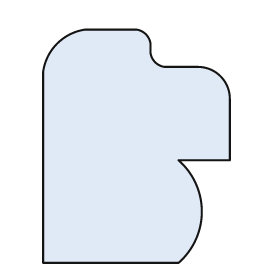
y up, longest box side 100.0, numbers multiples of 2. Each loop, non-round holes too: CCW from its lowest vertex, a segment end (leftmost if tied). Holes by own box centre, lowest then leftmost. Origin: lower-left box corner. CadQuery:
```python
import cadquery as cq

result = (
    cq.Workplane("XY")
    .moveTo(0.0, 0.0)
    .lineTo(58.0, 0.0)
    .threePointArc((68.0, 22.0), (58.0, 44.0))
    .lineTo(80.0, 44.0)
    .lineTo(80.0, 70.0)
    .threePointArc((76.0, 80.0), (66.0, 84.0))
    .lineTo(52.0, 84.0)
    .threePointArc((48.0, 86.0), (46.0, 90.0))
    .lineTo(46.0, 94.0)
    .threePointArc((44.0, 98.0), (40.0, 100.0))
    .lineTo(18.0, 100.0)
    .threePointArc((6.0, 94.0), (0.0, 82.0))
    .close()
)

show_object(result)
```